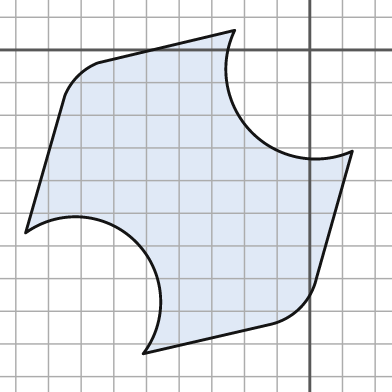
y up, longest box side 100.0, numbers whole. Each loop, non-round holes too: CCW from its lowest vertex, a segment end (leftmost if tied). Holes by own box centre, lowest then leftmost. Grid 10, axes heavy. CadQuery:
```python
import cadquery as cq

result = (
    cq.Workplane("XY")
    .moveTo(-51.0, -93.0)
    .lineTo(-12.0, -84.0)
    .threePointArc((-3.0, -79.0), (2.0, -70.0))
    .lineTo(13.0, -31.0)
    .threePointArc((-18.0, -25.0), (-23.0, 6.0))
    .lineTo(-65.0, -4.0)
    .threePointArc((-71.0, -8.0), (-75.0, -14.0))
    .lineTo(-87.0, -56.0)
    .threePointArc((-53.0, -59.0), (-51.0, -93.0))
    .close()
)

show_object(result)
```